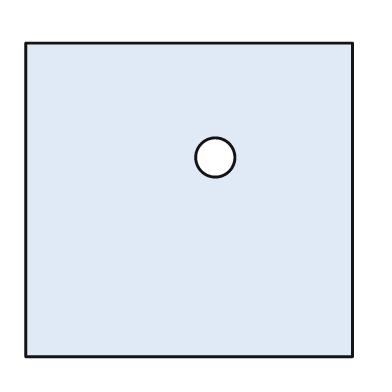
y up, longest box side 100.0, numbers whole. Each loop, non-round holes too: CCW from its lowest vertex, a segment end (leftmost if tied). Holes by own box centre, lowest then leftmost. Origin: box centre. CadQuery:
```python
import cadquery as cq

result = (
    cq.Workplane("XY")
    .moveTo(-50.0, -48.0)
    .lineTo(50.0, -48.0)
    .lineTo(50.0, 48.0)
    .lineTo(-50.0, 48.0)
    .close()
    .moveTo(8.0, 13.0)
    .circle(6.0)
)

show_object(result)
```